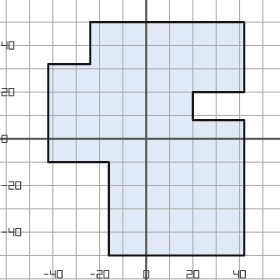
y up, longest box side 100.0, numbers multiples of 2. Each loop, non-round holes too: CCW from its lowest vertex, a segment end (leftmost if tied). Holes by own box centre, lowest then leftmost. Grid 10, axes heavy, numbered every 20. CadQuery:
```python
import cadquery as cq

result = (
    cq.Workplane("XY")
    .moveTo(-16.0, -50.0)
    .lineTo(42.0, -50.0)
    .lineTo(42.0, 8.0)
    .lineTo(20.0, 8.0)
    .lineTo(20.0, 20.0)
    .lineTo(42.0, 20.0)
    .lineTo(42.0, 50.0)
    .lineTo(-24.0, 50.0)
    .lineTo(-24.0, 32.0)
    .lineTo(-42.0, 32.0)
    .lineTo(-42.0, -10.0)
    .lineTo(-16.0, -10.0)
    .close()
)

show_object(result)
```